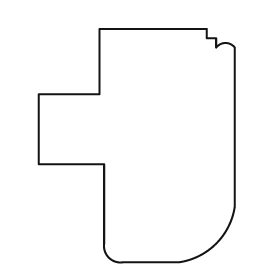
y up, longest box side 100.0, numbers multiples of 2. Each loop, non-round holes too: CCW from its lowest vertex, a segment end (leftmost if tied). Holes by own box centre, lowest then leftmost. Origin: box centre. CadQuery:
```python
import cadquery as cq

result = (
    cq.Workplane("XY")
    .moveTo(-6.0, -50.0)
    .lineTo(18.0, -50.0)
    .threePointArc((34.0, -42.0), (42.0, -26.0))
    .lineTo(42.0, 42.0)
    .threePointArc((38.0, 44.0), (34.0, 42.0))
    .lineTo(34.0, 46.0)
    .lineTo(30.0, 46.0)
    .lineTo(30.0, 50.0)
    .lineTo(-16.0, 50.0)
    .lineTo(-16.0, 22.0)
    .lineTo(-42.0, 22.0)
    .lineTo(-42.0, -8.0)
    .lineTo(-14.0, -8.0)
    .lineTo(-14.0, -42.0)
    .threePointArc((-12.0, -48.0), (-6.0, -50.0))
    .close()
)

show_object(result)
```